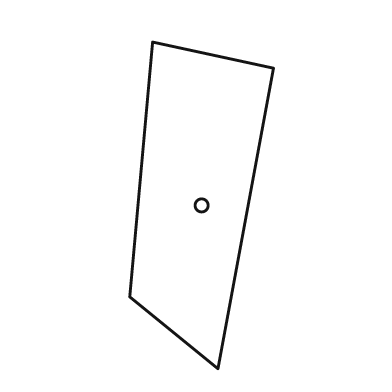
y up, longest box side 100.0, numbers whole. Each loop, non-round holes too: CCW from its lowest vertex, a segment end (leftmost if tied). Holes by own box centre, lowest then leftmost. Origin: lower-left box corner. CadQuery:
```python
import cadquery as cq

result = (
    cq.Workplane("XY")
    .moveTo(27.0, 0.0)
    .lineTo(44.0, 92.0)
    .lineTo(7.0, 100.0)
    .lineTo(0.0, 22.0)
    .close()
    .moveTo(22.0, 50.0)
    .circle(2.0)
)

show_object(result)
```